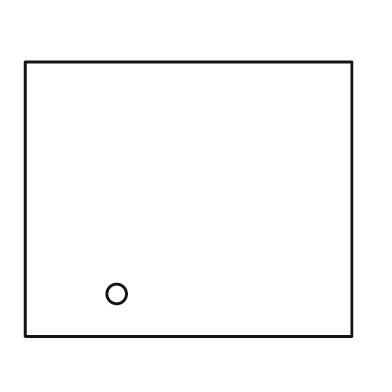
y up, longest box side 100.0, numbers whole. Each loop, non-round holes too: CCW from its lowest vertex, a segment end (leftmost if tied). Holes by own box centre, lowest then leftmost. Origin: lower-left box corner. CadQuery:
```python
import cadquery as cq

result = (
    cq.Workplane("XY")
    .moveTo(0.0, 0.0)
    .lineTo(100.0, 0.0)
    .lineTo(100.0, 84.0)
    .lineTo(0.0, 84.0)
    .close()
    .moveTo(28.0, 13.0)
    .circle(3.0)
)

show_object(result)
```